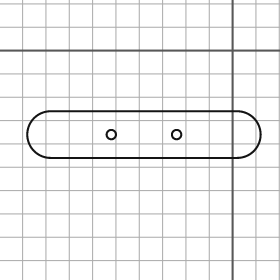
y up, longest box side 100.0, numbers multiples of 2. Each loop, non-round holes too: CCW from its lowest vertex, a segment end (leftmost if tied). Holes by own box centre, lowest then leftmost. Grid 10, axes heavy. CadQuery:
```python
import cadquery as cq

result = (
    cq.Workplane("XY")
    .moveTo(-78.0, -46.0)
    .lineTo(2.0, -46.0)
    .threePointArc((12.0, -36.0), (2.0, -26.0))
    .lineTo(-78.0, -26.0)
    .threePointArc((-88.0, -36.0), (-78.0, -46.0))
    .close()
    .moveTo(-52.0, -36.0)
    .circle(2.0)
    .moveTo(-24.0, -36.0)
    .circle(2.0)
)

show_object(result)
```